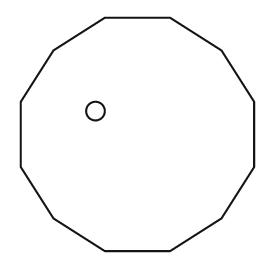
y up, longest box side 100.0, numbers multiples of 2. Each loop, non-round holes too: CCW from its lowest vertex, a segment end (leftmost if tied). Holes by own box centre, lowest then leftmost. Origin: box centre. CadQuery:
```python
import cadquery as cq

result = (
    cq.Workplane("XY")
    .moveTo(-14.0, -50.0)
    .lineTo(14.0, -50.0)
    .lineTo(36.0, -36.0)
    .lineTo(50.0, -14.0)
    .lineTo(50.0, 14.0)
    .lineTo(36.0, 36.0)
    .lineTo(14.0, 50.0)
    .lineTo(-14.0, 50.0)
    .lineTo(-36.0, 36.0)
    .lineTo(-50.0, 14.0)
    .lineTo(-50.0, -14.0)
    .lineTo(-36.0, -36.0)
    .close()
    .moveTo(-18.0, 10.0)
    .circle(4.0)
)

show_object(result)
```